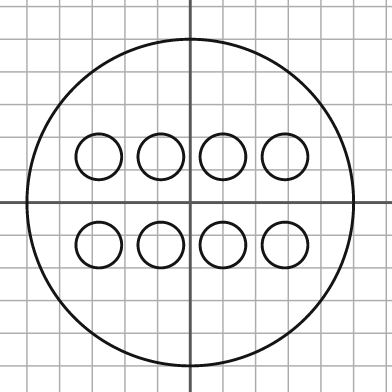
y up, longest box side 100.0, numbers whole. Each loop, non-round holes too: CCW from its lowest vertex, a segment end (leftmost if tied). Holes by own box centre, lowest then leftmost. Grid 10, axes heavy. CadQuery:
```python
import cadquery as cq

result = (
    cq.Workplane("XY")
    .moveTo(0.0, 0.0)
    .circle(50.0)
    .moveTo(-28.0, -13.0)
    .circle(7.0)
    .moveTo(-9.0, -13.0)
    .circle(7.0)
    .moveTo(10.0, -13.0)
    .circle(7.0)
    .moveTo(29.0, -13.0)
    .circle(7.0)
    .moveTo(-28.0, 14.0)
    .circle(7.0)
    .moveTo(-9.0, 14.0)
    .circle(7.0)
    .moveTo(10.0, 14.0)
    .circle(7.0)
    .moveTo(29.0, 14.0)
    .circle(7.0)
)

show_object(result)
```